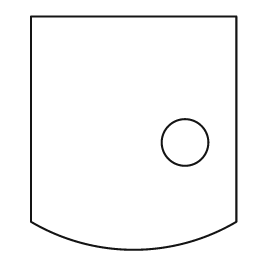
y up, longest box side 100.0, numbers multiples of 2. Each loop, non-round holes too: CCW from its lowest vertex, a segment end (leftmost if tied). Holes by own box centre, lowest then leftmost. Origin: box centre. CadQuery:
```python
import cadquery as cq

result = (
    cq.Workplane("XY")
    .moveTo(-44.0, -38.0)
    .threePointArc((0.0, -50.0), (44.0, -38.0))
    .lineTo(44.0, 50.0)
    .lineTo(-44.0, 50.0)
    .close()
    .moveTo(22.0, -4.0)
    .circle(10.0)
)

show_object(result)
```